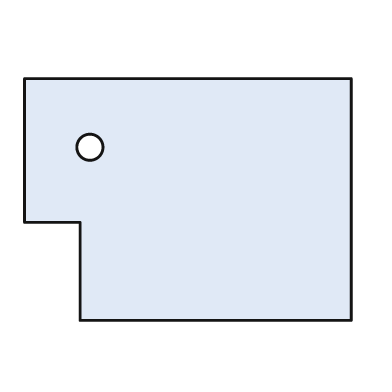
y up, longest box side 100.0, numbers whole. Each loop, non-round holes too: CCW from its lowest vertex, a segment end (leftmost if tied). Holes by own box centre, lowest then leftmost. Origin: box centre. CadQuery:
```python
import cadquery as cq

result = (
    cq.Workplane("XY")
    .moveTo(-33.0, -37.0)
    .lineTo(50.0, -37.0)
    .lineTo(50.0, 37.0)
    .lineTo(-50.0, 37.0)
    .lineTo(-50.0, -7.0)
    .lineTo(-33.0, -7.0)
    .close()
    .moveTo(-30.0, 16.0)
    .circle(4.0)
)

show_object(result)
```